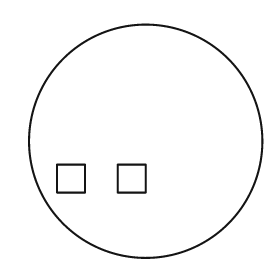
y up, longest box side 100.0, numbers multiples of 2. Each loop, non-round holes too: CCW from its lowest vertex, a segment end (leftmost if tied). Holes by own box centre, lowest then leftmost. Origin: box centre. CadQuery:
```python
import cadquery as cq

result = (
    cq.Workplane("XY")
    .moveTo(0.0, 0.0)
    .circle(50.0)
    .moveTo(-38.0, -22.0)
    .lineTo(-26.0, -22.0)
    .lineTo(-26.0, -10.0)
    .lineTo(-38.0, -10.0)
    .close()
    .moveTo(-12.0, -22.0)
    .lineTo(0.0, -22.0)
    .lineTo(0.0, -10.0)
    .lineTo(-12.0, -10.0)
    .close()
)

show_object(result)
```